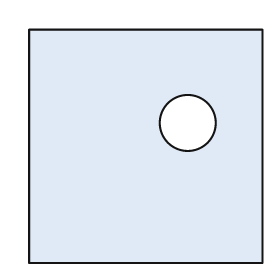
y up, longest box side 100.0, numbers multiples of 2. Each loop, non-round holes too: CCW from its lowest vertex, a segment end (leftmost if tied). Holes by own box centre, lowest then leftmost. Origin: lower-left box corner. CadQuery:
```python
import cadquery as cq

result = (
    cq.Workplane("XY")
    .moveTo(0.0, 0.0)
    .lineTo(100.0, 0.0)
    .lineTo(100.0, 100.0)
    .lineTo(0.0, 100.0)
    .close()
    .moveTo(68.0, 60.0)
    .circle(12.0)
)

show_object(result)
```